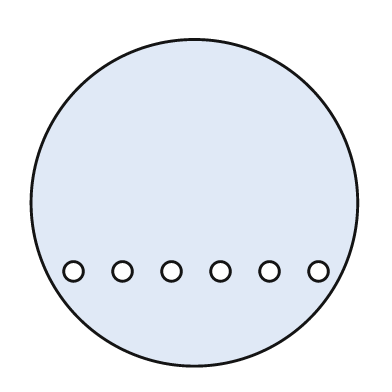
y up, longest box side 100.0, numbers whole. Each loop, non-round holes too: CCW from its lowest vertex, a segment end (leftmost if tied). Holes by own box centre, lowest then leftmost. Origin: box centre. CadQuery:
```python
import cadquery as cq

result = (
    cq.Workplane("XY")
    .moveTo(0.0, 0.0)
    .circle(50.0)
    .moveTo(-37.0, -21.0)
    .circle(3.0)
    .moveTo(-22.0, -21.0)
    .circle(3.0)
    .moveTo(-7.0, -21.0)
    .circle(3.0)
    .moveTo(8.0, -21.0)
    .circle(3.0)
    .moveTo(23.0, -21.0)
    .circle(3.0)
    .moveTo(38.0, -21.0)
    .circle(3.0)
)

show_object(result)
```